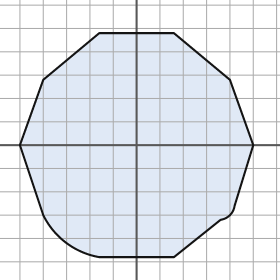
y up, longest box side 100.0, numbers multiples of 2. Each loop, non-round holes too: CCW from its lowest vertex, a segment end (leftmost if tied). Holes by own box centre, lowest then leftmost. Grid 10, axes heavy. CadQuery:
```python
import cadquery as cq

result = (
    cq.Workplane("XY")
    .moveTo(-16.0, -48.0)
    .lineTo(16.0, -48.0)
    .lineTo(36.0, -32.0)
    .threePointArc((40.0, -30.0), (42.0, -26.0))
    .lineTo(50.0, 0.0)
    .lineTo(40.0, 28.0)
    .lineTo(16.0, 48.0)
    .lineTo(-16.0, 48.0)
    .lineTo(-40.0, 28.0)
    .lineTo(-50.0, 0.0)
    .lineTo(-40.0, -30.0)
    .threePointArc((-30.0, -42.0), (-16.0, -48.0))
    .close()
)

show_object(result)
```